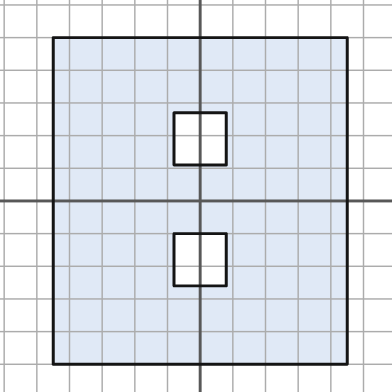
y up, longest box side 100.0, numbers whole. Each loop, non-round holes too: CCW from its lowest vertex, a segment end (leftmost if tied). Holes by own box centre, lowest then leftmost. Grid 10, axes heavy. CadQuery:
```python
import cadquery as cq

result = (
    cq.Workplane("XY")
    .moveTo(-45.0, -50.0)
    .lineTo(45.0, -50.0)
    .lineTo(45.0, 50.0)
    .lineTo(-45.0, 50.0)
    .close()
    .moveTo(-8.0, -26.0)
    .lineTo(8.0, -26.0)
    .lineTo(8.0, -10.0)
    .lineTo(-8.0, -10.0)
    .close()
    .moveTo(-8.0, 11.0)
    .lineTo(8.0, 11.0)
    .lineTo(8.0, 27.0)
    .lineTo(-8.0, 27.0)
    .close()
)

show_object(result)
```